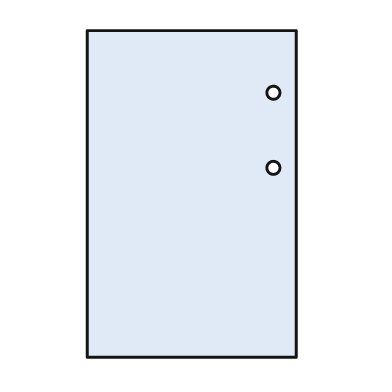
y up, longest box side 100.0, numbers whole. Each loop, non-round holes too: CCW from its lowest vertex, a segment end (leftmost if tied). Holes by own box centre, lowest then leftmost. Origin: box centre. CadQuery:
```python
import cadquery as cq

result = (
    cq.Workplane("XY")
    .moveTo(-32.0, -50.0)
    .lineTo(32.0, -50.0)
    .lineTo(32.0, 50.0)
    .lineTo(-32.0, 50.0)
    .close()
    .moveTo(25.0, 8.0)
    .circle(2.0)
    .moveTo(25.0, 31.0)
    .circle(2.0)
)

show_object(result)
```